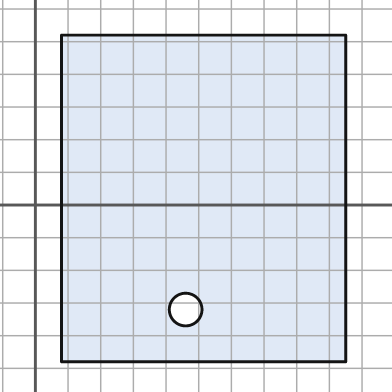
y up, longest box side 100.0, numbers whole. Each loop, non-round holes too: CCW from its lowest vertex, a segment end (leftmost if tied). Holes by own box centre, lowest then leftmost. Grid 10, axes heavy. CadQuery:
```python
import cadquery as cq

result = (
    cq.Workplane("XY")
    .moveTo(8.0, -48.0)
    .lineTo(95.0, -48.0)
    .lineTo(95.0, 52.0)
    .lineTo(8.0, 52.0)
    .close()
    .moveTo(46.0, -32.0)
    .circle(5.0)
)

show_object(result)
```